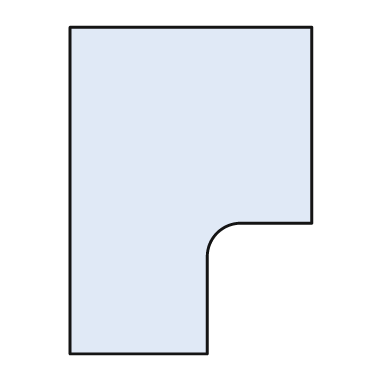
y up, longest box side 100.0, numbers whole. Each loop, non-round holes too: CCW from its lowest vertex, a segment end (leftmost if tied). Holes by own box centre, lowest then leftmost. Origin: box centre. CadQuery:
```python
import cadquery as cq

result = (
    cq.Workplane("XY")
    .moveTo(-37.0, -50.0)
    .lineTo(5.0, -50.0)
    .lineTo(5.0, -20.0)
    .threePointArc((8.0, -13.0), (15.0, -10.0))
    .lineTo(37.0, -10.0)
    .lineTo(37.0, 50.0)
    .lineTo(-37.0, 50.0)
    .close()
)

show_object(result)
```